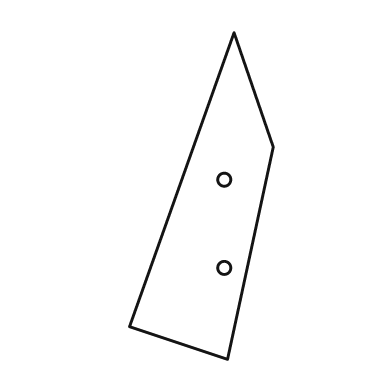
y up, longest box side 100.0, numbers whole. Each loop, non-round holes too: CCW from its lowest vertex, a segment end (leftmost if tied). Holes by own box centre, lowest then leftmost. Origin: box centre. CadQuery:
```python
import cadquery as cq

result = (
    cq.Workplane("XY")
    .moveTo(8.0, -50.0)
    .lineTo(22.0, 15.0)
    .lineTo(10.0, 50.0)
    .lineTo(-22.0, -40.0)
    .close()
    .moveTo(7.0, -22.0)
    .circle(2.0)
    .moveTo(7.0, 5.0)
    .circle(2.0)
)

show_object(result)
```